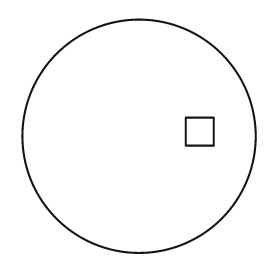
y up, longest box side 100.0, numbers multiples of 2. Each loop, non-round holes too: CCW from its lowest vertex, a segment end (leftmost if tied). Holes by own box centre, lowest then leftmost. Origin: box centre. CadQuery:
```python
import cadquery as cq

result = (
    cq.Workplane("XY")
    .moveTo(0.0, 0.0)
    .circle(50.0)
    .moveTo(20.0, -4.0)
    .lineTo(32.0, -4.0)
    .lineTo(32.0, 8.0)
    .lineTo(20.0, 8.0)
    .close()
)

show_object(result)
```